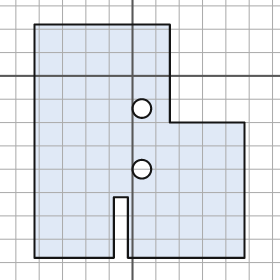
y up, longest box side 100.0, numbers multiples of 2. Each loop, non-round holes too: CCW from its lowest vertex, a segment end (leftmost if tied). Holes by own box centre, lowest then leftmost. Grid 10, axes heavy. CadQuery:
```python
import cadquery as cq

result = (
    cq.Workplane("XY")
    .moveTo(-42.0, -78.0)
    .lineTo(-8.0, -78.0)
    .lineTo(-8.0, -52.0)
    .lineTo(-2.0, -52.0)
    .lineTo(-2.0, -78.0)
    .lineTo(48.0, -78.0)
    .lineTo(48.0, -20.0)
    .lineTo(16.0, -20.0)
    .lineTo(16.0, 22.0)
    .lineTo(-42.0, 22.0)
    .close()
    .moveTo(4.0, -40.0)
    .circle(4.0)
    .moveTo(4.0, -14.0)
    .circle(4.0)
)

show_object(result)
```